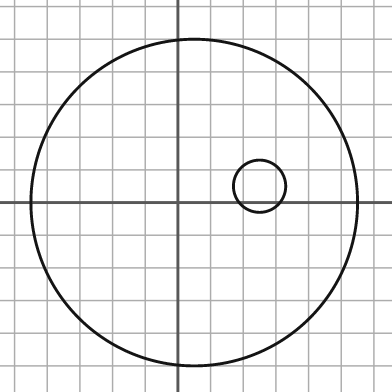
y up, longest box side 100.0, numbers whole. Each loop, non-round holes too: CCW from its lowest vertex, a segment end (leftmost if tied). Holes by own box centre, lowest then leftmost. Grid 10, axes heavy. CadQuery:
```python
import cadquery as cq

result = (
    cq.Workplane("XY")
    .moveTo(5.0, 0.0)
    .circle(50.0)
    .moveTo(25.0, 5.0)
    .circle(8.0)
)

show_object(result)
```